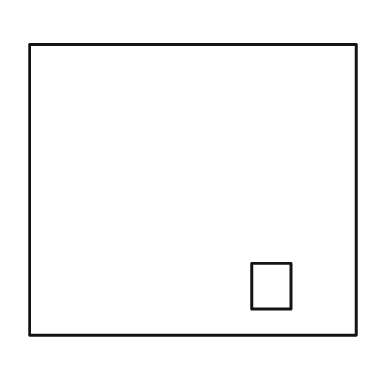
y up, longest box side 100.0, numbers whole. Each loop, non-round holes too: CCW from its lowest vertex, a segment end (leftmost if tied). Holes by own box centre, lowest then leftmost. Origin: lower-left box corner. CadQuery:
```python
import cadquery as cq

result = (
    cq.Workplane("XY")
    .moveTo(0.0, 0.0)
    .lineTo(100.0, 0.0)
    .lineTo(100.0, 89.0)
    .lineTo(0.0, 89.0)
    .close()
    .moveTo(68.0, 8.0)
    .lineTo(80.0, 8.0)
    .lineTo(80.0, 22.0)
    .lineTo(68.0, 22.0)
    .close()
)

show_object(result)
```